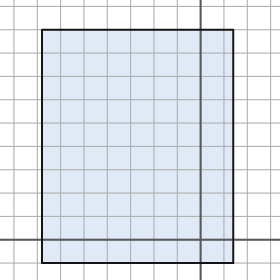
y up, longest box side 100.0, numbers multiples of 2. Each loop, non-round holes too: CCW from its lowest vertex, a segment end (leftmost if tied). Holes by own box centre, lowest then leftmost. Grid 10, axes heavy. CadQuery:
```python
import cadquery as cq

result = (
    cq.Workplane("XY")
    .moveTo(-68.0, -10.0)
    .lineTo(14.0, -10.0)
    .lineTo(14.0, 90.0)
    .lineTo(-68.0, 90.0)
    .close()
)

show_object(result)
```